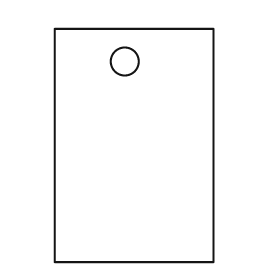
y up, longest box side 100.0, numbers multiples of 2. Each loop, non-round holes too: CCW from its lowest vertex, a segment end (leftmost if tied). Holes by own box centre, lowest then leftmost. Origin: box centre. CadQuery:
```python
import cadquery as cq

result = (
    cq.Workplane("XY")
    .moveTo(-34.0, -50.0)
    .lineTo(34.0, -50.0)
    .lineTo(34.0, 50.0)
    .lineTo(-34.0, 50.0)
    .close()
    .moveTo(-4.0, 36.0)
    .circle(6.0)
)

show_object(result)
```